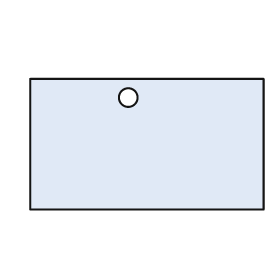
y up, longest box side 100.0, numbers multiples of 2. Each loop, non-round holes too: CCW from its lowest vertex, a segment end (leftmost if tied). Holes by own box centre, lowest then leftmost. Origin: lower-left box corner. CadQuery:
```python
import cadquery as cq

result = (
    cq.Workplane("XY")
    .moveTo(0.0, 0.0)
    .lineTo(100.0, 0.0)
    .lineTo(100.0, 56.0)
    .lineTo(0.0, 56.0)
    .close()
    .moveTo(42.0, 48.0)
    .circle(4.0)
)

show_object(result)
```